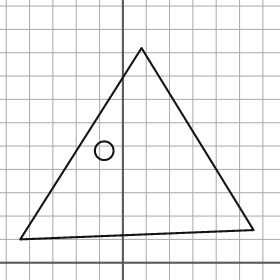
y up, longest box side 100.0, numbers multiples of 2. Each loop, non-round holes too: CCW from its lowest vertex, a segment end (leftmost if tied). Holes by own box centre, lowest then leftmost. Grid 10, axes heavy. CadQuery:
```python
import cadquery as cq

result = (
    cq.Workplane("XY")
    .moveTo(-44.0, 10.0)
    .lineTo(56.0, 14.0)
    .lineTo(8.0, 92.0)
    .close()
    .moveTo(-8.0, 48.0)
    .circle(4.0)
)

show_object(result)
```